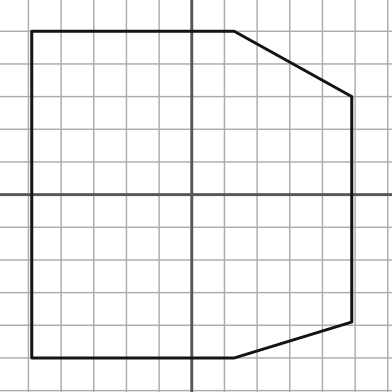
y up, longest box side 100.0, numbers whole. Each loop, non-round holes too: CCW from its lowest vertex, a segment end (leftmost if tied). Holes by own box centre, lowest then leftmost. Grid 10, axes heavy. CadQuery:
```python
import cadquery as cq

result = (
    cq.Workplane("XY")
    .moveTo(-49.0, -50.0)
    .lineTo(13.0, -50.0)
    .lineTo(49.0, -39.0)
    .lineTo(49.0, 30.0)
    .lineTo(13.0, 50.0)
    .lineTo(-49.0, 50.0)
    .close()
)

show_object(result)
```